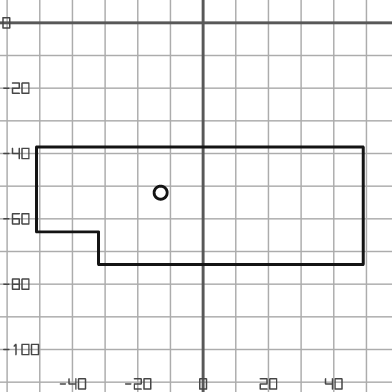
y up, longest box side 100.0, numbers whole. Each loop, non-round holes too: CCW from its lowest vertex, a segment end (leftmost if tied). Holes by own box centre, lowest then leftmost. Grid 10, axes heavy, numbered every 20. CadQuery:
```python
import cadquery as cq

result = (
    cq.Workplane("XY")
    .moveTo(-32.0, -74.0)
    .lineTo(49.0, -74.0)
    .lineTo(49.0, -38.0)
    .lineTo(-51.0, -38.0)
    .lineTo(-51.0, -64.0)
    .lineTo(-32.0, -64.0)
    .close()
    .moveTo(-13.0, -52.0)
    .circle(2.0)
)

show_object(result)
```